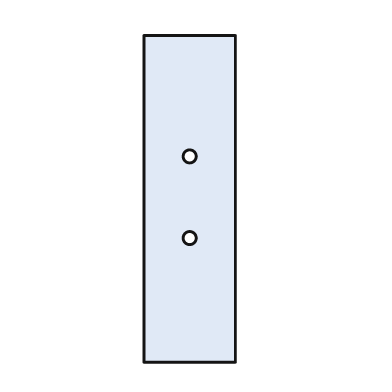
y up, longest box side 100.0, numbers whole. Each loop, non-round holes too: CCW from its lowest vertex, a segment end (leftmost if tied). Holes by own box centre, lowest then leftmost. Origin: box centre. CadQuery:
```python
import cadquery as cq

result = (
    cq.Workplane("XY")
    .moveTo(-14.0, -50.0)
    .lineTo(14.0, -50.0)
    .lineTo(14.0, 50.0)
    .lineTo(-14.0, 50.0)
    .close()
    .moveTo(0.0, -12.0)
    .circle(2.0)
    .moveTo(0.0, 13.0)
    .circle(2.0)
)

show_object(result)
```